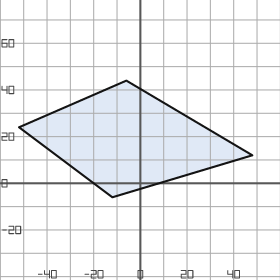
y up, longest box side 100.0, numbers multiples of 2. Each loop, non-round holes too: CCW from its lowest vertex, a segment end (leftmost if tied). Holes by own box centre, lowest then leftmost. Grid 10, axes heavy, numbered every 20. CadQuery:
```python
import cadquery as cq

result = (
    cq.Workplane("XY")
    .moveTo(-12.0, -6.0)
    .lineTo(48.0, 12.0)
    .lineTo(-6.0, 44.0)
    .lineTo(-52.0, 24.0)
    .close()
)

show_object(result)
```